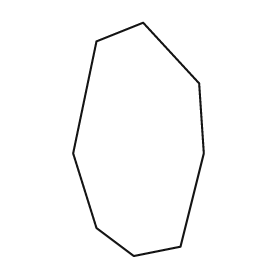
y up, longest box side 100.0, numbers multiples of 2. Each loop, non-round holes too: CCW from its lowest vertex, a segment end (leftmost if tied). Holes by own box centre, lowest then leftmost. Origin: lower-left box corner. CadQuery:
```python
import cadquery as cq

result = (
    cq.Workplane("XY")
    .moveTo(26.0, 0.0)
    .lineTo(46.0, 4.0)
    .lineTo(56.0, 44.0)
    .lineTo(54.0, 74.0)
    .lineTo(30.0, 100.0)
    .lineTo(10.0, 92.0)
    .lineTo(0.0, 44.0)
    .lineTo(10.0, 12.0)
    .close()
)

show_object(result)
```